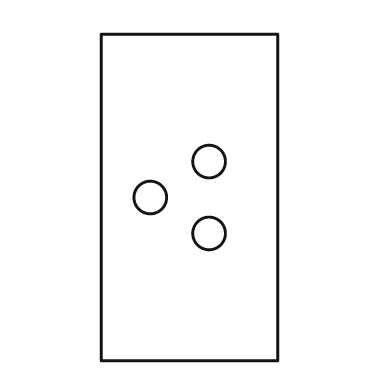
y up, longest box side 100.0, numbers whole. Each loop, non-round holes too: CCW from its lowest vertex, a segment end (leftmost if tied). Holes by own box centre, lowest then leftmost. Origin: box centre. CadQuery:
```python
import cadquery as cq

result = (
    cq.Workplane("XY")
    .moveTo(-27.0, -50.0)
    .lineTo(27.0, -50.0)
    .lineTo(27.0, 50.0)
    .lineTo(-27.0, 50.0)
    .close()
    .moveTo(6.0, -11.0)
    .circle(5.0)
    .moveTo(-12.0, 0.0)
    .circle(5.0)
    .moveTo(6.0, 11.0)
    .circle(5.0)
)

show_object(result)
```